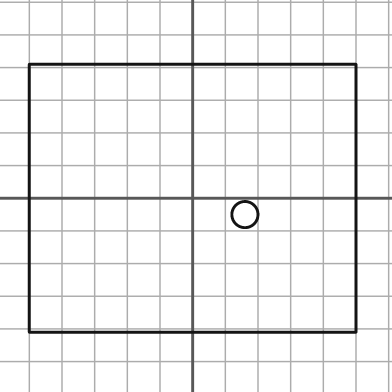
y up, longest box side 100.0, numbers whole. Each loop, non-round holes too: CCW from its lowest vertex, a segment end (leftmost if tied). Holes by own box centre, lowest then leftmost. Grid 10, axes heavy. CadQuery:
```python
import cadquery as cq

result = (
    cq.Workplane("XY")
    .moveTo(-50.0, -41.0)
    .lineTo(50.0, -41.0)
    .lineTo(50.0, 41.0)
    .lineTo(-50.0, 41.0)
    .close()
    .moveTo(16.0, -5.0)
    .circle(4.0)
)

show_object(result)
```